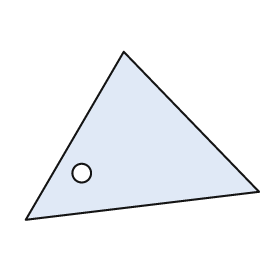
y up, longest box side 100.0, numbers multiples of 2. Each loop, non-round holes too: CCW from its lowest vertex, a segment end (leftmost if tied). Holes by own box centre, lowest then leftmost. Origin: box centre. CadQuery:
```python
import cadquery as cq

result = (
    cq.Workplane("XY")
    .moveTo(-50.0, -36.0)
    .lineTo(50.0, -24.0)
    .lineTo(-8.0, 36.0)
    .close()
    .moveTo(-26.0, -16.0)
    .circle(4.0)
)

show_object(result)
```